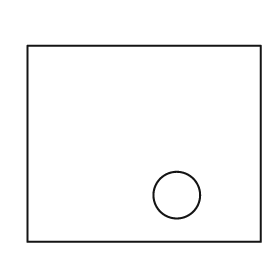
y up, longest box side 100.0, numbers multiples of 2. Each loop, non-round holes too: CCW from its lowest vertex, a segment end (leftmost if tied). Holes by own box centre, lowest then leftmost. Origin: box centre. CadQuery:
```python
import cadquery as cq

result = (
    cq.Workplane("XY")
    .moveTo(-50.0, -42.0)
    .lineTo(50.0, -42.0)
    .lineTo(50.0, 42.0)
    .lineTo(-50.0, 42.0)
    .close()
    .moveTo(14.0, -22.0)
    .circle(10.0)
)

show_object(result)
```